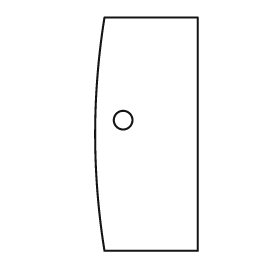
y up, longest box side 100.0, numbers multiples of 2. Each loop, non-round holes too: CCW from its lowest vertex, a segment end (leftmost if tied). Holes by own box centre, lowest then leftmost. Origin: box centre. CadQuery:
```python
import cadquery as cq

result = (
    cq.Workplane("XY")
    .moveTo(-18.0, -50.0)
    .lineTo(22.0, -50.0)
    .lineTo(22.0, 50.0)
    .lineTo(-18.0, 50.0)
    .threePointArc((-22.0, 0.0), (-18.0, -50.0))
    .close()
    .moveTo(-10.0, 6.0)
    .circle(4.0)
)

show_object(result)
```